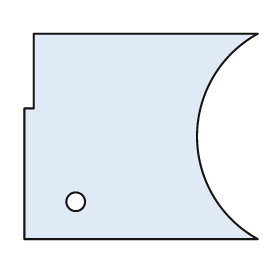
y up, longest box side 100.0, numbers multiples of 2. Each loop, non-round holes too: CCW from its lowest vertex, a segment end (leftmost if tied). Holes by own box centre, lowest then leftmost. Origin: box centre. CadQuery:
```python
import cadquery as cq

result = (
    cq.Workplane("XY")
    .moveTo(-50.0, -44.0)
    .lineTo(50.0, -44.0)
    .threePointArc((24.0, 0.0), (50.0, 44.0))
    .lineTo(-46.0, 44.0)
    .lineTo(-46.0, 12.0)
    .lineTo(-50.0, 12.0)
    .close()
    .moveTo(-28.0, -28.0)
    .circle(4.0)
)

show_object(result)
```